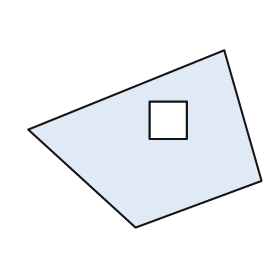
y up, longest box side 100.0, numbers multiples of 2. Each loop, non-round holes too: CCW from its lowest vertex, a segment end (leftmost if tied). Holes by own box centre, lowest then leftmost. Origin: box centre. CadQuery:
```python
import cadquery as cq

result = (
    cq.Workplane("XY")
    .moveTo(-4.0, -38.0)
    .lineTo(50.0, -18.0)
    .lineTo(34.0, 38.0)
    .lineTo(-50.0, 4.0)
    .close()
    .moveTo(2.0, 0.0)
    .lineTo(18.0, 0.0)
    .lineTo(18.0, 16.0)
    .lineTo(2.0, 16.0)
    .close()
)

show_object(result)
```